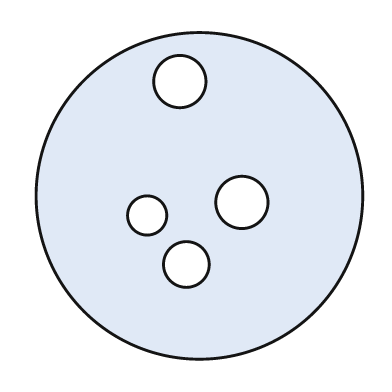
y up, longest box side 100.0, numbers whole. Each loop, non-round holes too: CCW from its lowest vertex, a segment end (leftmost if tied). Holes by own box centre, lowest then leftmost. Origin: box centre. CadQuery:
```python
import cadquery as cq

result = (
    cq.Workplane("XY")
    .moveTo(0.0, 0.0)
    .circle(50.0)
    .moveTo(-4.0, -21.0)
    .circle(7.0)
    .moveTo(-16.0, -6.0)
    .circle(6.0)
    .moveTo(13.0, -2.0)
    .circle(8.0)
    .moveTo(-6.0, 35.0)
    .circle(8.0)
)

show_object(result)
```